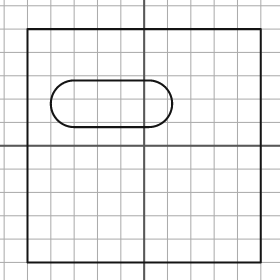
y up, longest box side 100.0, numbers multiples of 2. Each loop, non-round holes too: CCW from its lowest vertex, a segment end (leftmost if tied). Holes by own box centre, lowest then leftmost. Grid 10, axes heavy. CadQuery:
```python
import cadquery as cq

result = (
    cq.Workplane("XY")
    .moveTo(-50.0, -50.0)
    .lineTo(50.0, -50.0)
    .lineTo(50.0, 50.0)
    .lineTo(-50.0, 50.0)
    .close()
    .moveTo(-30.0, 8.0)
    .lineTo(2.0, 8.0)
    .threePointArc((12.0, 18.0), (2.0, 28.0))
    .lineTo(-30.0, 28.0)
    .threePointArc((-40.0, 18.0), (-30.0, 8.0))
    .close()
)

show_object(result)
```